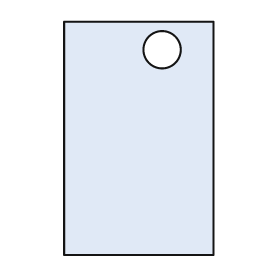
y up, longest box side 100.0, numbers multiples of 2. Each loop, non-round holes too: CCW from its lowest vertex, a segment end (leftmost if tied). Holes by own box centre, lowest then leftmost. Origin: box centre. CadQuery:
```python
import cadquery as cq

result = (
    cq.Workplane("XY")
    .moveTo(-32.0, -50.0)
    .lineTo(32.0, -50.0)
    .lineTo(32.0, 50.0)
    .lineTo(-32.0, 50.0)
    .close()
    .moveTo(10.0, 38.0)
    .circle(8.0)
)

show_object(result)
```